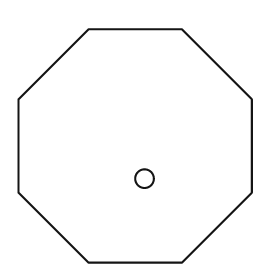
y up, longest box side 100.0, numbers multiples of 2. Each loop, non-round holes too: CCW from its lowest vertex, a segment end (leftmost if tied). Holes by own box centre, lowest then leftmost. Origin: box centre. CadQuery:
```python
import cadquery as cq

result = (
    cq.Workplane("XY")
    .moveTo(-20.0, -50.0)
    .lineTo(20.0, -50.0)
    .lineTo(50.0, -20.0)
    .lineTo(50.0, 20.0)
    .lineTo(20.0, 50.0)
    .lineTo(-20.0, 50.0)
    .lineTo(-50.0, 20.0)
    .lineTo(-50.0, -20.0)
    .close()
    .moveTo(4.0, -14.0)
    .circle(4.0)
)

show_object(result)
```